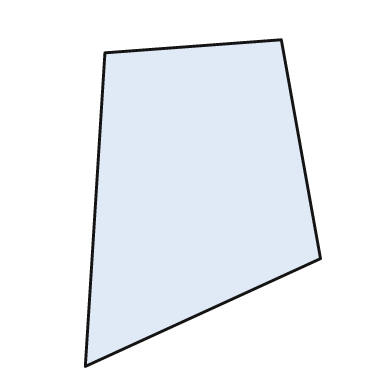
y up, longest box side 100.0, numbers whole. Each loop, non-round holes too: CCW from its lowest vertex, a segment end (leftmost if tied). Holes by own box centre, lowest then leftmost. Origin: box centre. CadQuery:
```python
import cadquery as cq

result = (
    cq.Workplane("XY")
    .moveTo(-36.0, -50.0)
    .lineTo(36.0, -17.0)
    .lineTo(24.0, 50.0)
    .lineTo(-30.0, 46.0)
    .close()
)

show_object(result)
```